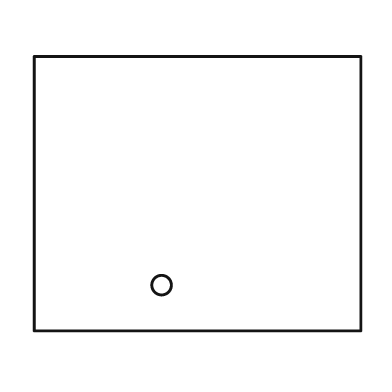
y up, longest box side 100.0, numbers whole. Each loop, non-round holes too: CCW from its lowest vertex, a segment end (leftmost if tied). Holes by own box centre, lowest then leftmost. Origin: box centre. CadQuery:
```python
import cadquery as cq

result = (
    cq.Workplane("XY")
    .moveTo(-50.0, -42.0)
    .lineTo(50.0, -42.0)
    .lineTo(50.0, 42.0)
    .lineTo(-50.0, 42.0)
    .close()
    .moveTo(-11.0, -28.0)
    .circle(3.0)
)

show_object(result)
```